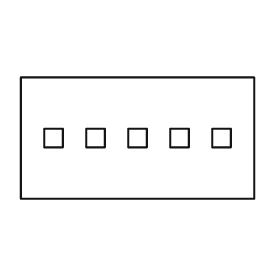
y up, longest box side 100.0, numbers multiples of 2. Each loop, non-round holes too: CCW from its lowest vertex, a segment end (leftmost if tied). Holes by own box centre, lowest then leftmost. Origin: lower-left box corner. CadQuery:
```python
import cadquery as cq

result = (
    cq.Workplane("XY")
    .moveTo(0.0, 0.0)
    .lineTo(100.0, 0.0)
    .lineTo(100.0, 52.0)
    .lineTo(0.0, 52.0)
    .close()
    .moveTo(10.0, 22.0)
    .lineTo(18.0, 22.0)
    .lineTo(18.0, 30.0)
    .lineTo(10.0, 30.0)
    .close()
    .moveTo(28.0, 22.0)
    .lineTo(36.0, 22.0)
    .lineTo(36.0, 30.0)
    .lineTo(28.0, 30.0)
    .close()
    .moveTo(46.0, 22.0)
    .lineTo(54.0, 22.0)
    .lineTo(54.0, 30.0)
    .lineTo(46.0, 30.0)
    .close()
    .moveTo(64.0, 22.0)
    .lineTo(72.0, 22.0)
    .lineTo(72.0, 30.0)
    .lineTo(64.0, 30.0)
    .close()
    .moveTo(82.0, 22.0)
    .lineTo(90.0, 22.0)
    .lineTo(90.0, 30.0)
    .lineTo(82.0, 30.0)
    .close()
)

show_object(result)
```